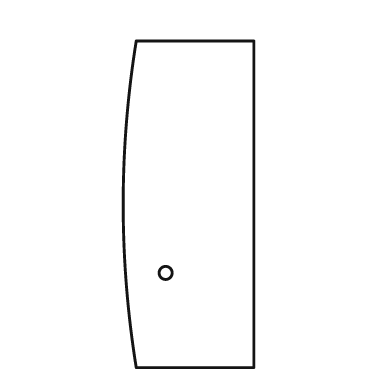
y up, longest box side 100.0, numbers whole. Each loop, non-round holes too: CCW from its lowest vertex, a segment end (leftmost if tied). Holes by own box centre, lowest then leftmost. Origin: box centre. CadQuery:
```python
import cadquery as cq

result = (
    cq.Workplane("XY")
    .moveTo(-16.0, -50.0)
    .lineTo(20.0, -50.0)
    .lineTo(20.0, 50.0)
    .lineTo(-16.0, 50.0)
    .threePointArc((-20.0, 0.0), (-16.0, -50.0))
    .close()
    .moveTo(-7.0, -21.0)
    .circle(2.0)
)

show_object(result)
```